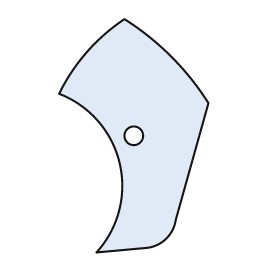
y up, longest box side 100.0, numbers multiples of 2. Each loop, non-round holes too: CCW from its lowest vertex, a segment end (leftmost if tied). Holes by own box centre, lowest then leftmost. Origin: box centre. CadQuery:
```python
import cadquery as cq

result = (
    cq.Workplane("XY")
    .moveTo(-16.0, -50.0)
    .lineTo(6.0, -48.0)
    .threePointArc((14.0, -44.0), (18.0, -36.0))
    .lineTo(32.0, 14.0)
    .threePointArc((16.0, 34.0), (-4.0, 50.0))
    .threePointArc((-20.0, 36.0), (-32.0, 18.0))
    .threePointArc((-6.0, -12.0), (-16.0, -50.0))
    .close()
    .moveTo(0.0, 0.0)
    .circle(4.0)
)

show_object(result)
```